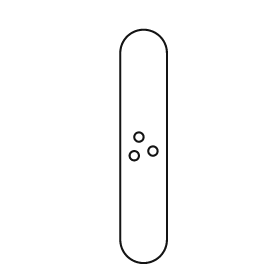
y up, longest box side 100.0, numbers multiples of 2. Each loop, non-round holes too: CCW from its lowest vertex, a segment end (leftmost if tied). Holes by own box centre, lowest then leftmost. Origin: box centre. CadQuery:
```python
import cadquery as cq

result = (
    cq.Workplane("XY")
    .moveTo(-10.0, -40.0)
    .threePointArc((0.0, -50.0), (10.0, -40.0))
    .lineTo(10.0, 40.0)
    .threePointArc((0.0, 50.0), (-10.0, 40.0))
    .close()
    .moveTo(-4.0, -4.0)
    .circle(2.0)
    .moveTo(4.0, -2.0)
    .circle(2.0)
    .moveTo(-2.0, 4.0)
    .circle(2.0)
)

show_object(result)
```